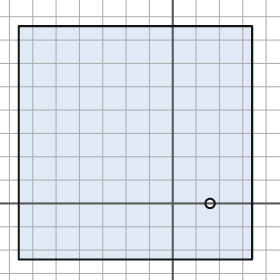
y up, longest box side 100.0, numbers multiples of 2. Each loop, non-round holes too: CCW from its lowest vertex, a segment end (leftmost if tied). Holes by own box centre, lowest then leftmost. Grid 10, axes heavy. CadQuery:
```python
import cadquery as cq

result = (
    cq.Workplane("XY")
    .moveTo(-66.0, -24.0)
    .lineTo(34.0, -24.0)
    .lineTo(34.0, 76.0)
    .lineTo(-66.0, 76.0)
    .close()
    .moveTo(16.0, 0.0)
    .circle(2.0)
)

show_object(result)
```